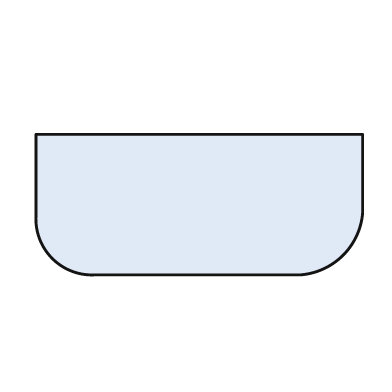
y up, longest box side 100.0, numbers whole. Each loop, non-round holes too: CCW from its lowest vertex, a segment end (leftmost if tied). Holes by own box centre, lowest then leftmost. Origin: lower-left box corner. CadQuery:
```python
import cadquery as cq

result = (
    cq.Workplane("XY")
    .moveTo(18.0, 0.0)
    .lineTo(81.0, 0.0)
    .threePointArc((94.0, 6.0), (100.0, 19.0))
    .lineTo(100.0, 43.0)
    .lineTo(0.0, 43.0)
    .lineTo(0.0, 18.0)
    .threePointArc((5.0, 5.0), (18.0, 0.0))
    .close()
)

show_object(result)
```